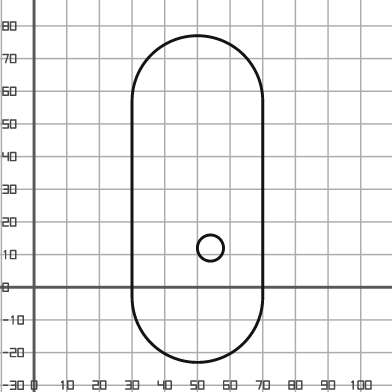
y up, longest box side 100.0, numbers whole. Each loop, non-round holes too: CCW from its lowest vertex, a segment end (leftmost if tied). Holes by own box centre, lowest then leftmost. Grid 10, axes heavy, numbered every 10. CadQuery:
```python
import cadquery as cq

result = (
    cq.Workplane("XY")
    .moveTo(30.0, -3.0)
    .threePointArc((50.0, -23.0), (70.0, -3.0))
    .lineTo(70.0, 57.0)
    .threePointArc((50.0, 77.0), (30.0, 57.0))
    .close()
    .moveTo(54.0, 12.0)
    .circle(4.0)
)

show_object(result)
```